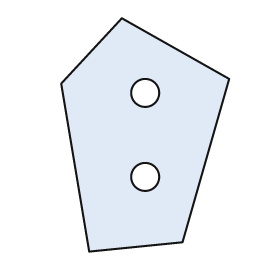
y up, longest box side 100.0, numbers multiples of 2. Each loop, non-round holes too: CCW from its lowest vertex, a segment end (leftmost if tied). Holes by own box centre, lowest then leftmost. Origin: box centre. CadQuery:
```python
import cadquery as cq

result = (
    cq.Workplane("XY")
    .moveTo(-24.0, -50.0)
    .lineTo(16.0, -46.0)
    .lineTo(36.0, 24.0)
    .lineTo(-10.0, 50.0)
    .lineTo(-36.0, 22.0)
    .close()
    .moveTo(0.0, -18.0)
    .circle(6.0)
    .moveTo(0.0, 18.0)
    .circle(6.0)
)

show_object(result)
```